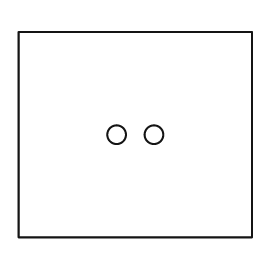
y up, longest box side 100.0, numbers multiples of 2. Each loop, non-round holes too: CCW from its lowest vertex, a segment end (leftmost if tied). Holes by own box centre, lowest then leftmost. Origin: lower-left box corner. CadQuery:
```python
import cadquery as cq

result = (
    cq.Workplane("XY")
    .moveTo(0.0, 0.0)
    .lineTo(100.0, 0.0)
    .lineTo(100.0, 88.0)
    .lineTo(0.0, 88.0)
    .close()
    .moveTo(42.0, 44.0)
    .circle(4.0)
    .moveTo(58.0, 44.0)
    .circle(4.0)
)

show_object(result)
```